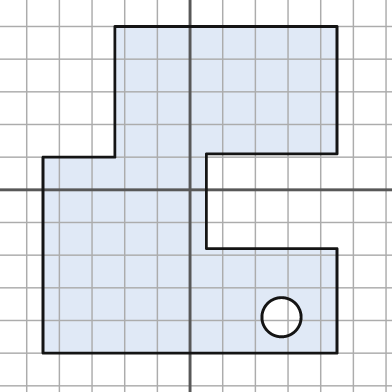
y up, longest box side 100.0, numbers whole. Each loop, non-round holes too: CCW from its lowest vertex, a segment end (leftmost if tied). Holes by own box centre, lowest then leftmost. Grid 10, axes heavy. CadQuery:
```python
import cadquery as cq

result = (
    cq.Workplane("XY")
    .moveTo(-45.0, -50.0)
    .lineTo(45.0, -50.0)
    .lineTo(45.0, -18.0)
    .lineTo(5.0, -18.0)
    .lineTo(5.0, 11.0)
    .lineTo(45.0, 11.0)
    .lineTo(45.0, 50.0)
    .lineTo(-23.0, 50.0)
    .lineTo(-23.0, 10.0)
    .lineTo(-45.0, 10.0)
    .close()
    .moveTo(28.0, -39.0)
    .circle(6.0)
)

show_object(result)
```